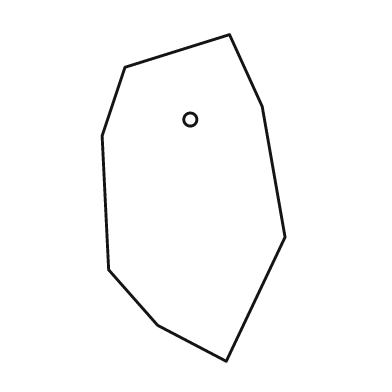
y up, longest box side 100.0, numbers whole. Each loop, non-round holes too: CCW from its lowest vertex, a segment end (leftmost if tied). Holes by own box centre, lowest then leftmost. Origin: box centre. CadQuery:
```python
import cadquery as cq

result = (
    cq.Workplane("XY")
    .moveTo(10.0, -50.0)
    .lineTo(28.0, -12.0)
    .lineTo(21.0, 28.0)
    .lineTo(11.0, 50.0)
    .lineTo(-21.0, 40.0)
    .lineTo(-28.0, 19.0)
    .lineTo(-26.0, -22.0)
    .lineTo(-11.0, -39.0)
    .close()
    .moveTo(-1.0, 24.0)
    .circle(2.0)
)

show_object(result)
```